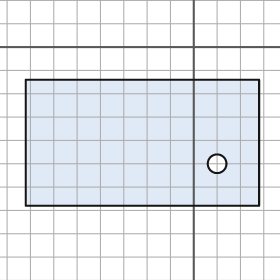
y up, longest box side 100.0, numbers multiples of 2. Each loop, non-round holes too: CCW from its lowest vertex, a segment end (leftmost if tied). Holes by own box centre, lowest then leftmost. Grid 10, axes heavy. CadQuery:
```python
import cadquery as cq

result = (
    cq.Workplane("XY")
    .moveTo(-72.0, -68.0)
    .lineTo(28.0, -68.0)
    .lineTo(28.0, -14.0)
    .lineTo(-72.0, -14.0)
    .close()
    .moveTo(10.0, -50.0)
    .circle(4.0)
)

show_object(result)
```